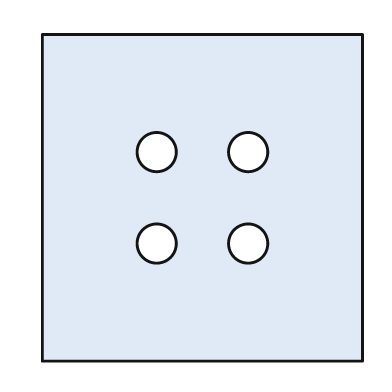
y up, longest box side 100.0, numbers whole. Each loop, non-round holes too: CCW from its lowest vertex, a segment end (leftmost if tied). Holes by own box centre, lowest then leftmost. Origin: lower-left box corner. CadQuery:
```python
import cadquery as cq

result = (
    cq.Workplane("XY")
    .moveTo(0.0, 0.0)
    .lineTo(98.0, 0.0)
    .lineTo(98.0, 100.0)
    .lineTo(0.0, 100.0)
    .close()
    .moveTo(35.0, 36.0)
    .circle(6.0)
    .moveTo(63.0, 36.0)
    .circle(6.0)
    .moveTo(35.0, 64.0)
    .circle(6.0)
    .moveTo(63.0, 64.0)
    .circle(6.0)
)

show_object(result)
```